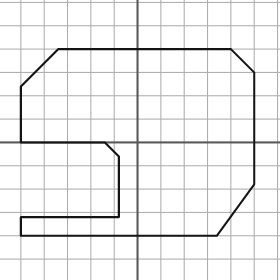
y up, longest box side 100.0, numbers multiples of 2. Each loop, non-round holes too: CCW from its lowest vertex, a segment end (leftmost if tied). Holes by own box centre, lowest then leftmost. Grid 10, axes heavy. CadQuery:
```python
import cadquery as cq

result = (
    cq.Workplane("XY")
    .moveTo(-50.0, -40.0)
    .lineTo(34.0, -40.0)
    .lineTo(50.0, -18.0)
    .lineTo(50.0, 30.0)
    .lineTo(40.0, 40.0)
    .lineTo(-34.0, 40.0)
    .lineTo(-50.0, 24.0)
    .lineTo(-50.0, 0.0)
    .lineTo(-14.0, 0.0)
    .lineTo(-8.0, -6.0)
    .lineTo(-8.0, -32.0)
    .lineTo(-50.0, -32.0)
    .close()
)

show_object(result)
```